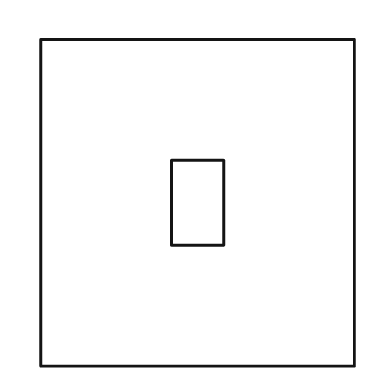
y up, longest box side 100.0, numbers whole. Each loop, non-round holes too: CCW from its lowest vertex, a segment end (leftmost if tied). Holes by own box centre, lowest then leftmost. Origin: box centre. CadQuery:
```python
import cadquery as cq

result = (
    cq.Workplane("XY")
    .moveTo(-48.0, -50.0)
    .lineTo(48.0, -50.0)
    .lineTo(48.0, 50.0)
    .lineTo(-48.0, 50.0)
    .close()
    .moveTo(-8.0, -13.0)
    .lineTo(8.0, -13.0)
    .lineTo(8.0, 13.0)
    .lineTo(-8.0, 13.0)
    .close()
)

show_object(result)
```